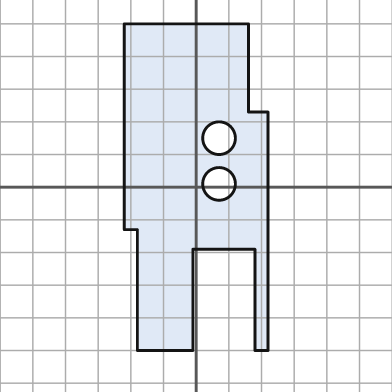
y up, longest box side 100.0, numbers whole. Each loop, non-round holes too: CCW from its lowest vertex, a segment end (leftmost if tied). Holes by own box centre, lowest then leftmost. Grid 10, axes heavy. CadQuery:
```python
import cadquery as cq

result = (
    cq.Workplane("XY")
    .moveTo(-18.0, -50.0)
    .lineTo(-1.0, -50.0)
    .lineTo(-1.0, -19.0)
    .lineTo(18.0, -19.0)
    .lineTo(18.0, -50.0)
    .lineTo(22.0, -50.0)
    .lineTo(22.0, 23.0)
    .lineTo(16.0, 23.0)
    .lineTo(16.0, 50.0)
    .lineTo(-22.0, 50.0)
    .lineTo(-22.0, -13.0)
    .lineTo(-18.0, -13.0)
    .close()
    .moveTo(7.0, 1.0)
    .circle(5.0)
    .moveTo(7.0, 15.0)
    .circle(5.0)
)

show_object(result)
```